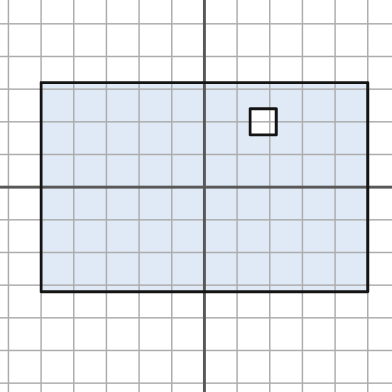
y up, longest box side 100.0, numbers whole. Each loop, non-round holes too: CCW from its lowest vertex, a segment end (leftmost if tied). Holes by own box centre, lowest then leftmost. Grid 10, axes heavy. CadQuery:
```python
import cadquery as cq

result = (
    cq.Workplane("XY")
    .moveTo(-50.0, -32.0)
    .lineTo(50.0, -32.0)
    .lineTo(50.0, 32.0)
    .lineTo(-50.0, 32.0)
    .close()
    .moveTo(14.0, 16.0)
    .lineTo(22.0, 16.0)
    .lineTo(22.0, 24.0)
    .lineTo(14.0, 24.0)
    .close()
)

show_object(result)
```